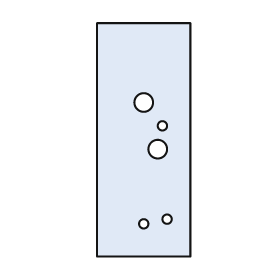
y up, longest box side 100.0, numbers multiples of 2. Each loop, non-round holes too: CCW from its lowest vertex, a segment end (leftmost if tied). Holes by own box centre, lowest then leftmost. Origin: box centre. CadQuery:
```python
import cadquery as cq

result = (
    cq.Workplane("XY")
    .moveTo(-20.0, -50.0)
    .lineTo(20.0, -50.0)
    .lineTo(20.0, 50.0)
    .lineTo(-20.0, 50.0)
    .close()
    .moveTo(0.0, -36.0)
    .circle(2.0)
    .moveTo(10.0, -34.0)
    .circle(2.0)
    .moveTo(6.0, -4.0)
    .circle(4.0)
    .moveTo(8.0, 6.0)
    .circle(2.0)
    .moveTo(0.0, 16.0)
    .circle(4.0)
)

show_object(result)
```